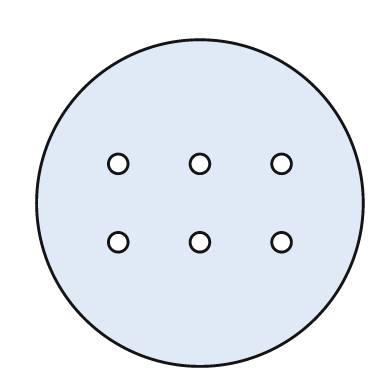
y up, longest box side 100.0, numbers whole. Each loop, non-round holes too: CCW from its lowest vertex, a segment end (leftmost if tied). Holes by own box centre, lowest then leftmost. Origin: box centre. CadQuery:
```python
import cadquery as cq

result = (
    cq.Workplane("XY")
    .moveTo(0.0, 0.0)
    .circle(50.0)
    .moveTo(-25.0, -12.0)
    .circle(3.0)
    .moveTo(0.0, -12.0)
    .circle(3.0)
    .moveTo(25.0, -12.0)
    .circle(3.0)
    .moveTo(-25.0, 12.0)
    .circle(3.0)
    .moveTo(0.0, 12.0)
    .circle(3.0)
    .moveTo(25.0, 12.0)
    .circle(3.0)
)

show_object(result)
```